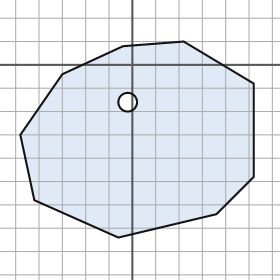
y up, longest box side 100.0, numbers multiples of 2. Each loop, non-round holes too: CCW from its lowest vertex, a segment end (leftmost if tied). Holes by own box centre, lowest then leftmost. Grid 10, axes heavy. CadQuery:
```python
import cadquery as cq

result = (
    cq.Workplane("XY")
    .moveTo(-6.0, -74.0)
    .lineTo(36.0, -64.0)
    .lineTo(52.0, -48.0)
    .lineTo(52.0, -8.0)
    .lineTo(22.0, 10.0)
    .lineTo(-4.0, 8.0)
    .lineTo(-30.0, -4.0)
    .lineTo(-48.0, -30.0)
    .lineTo(-42.0, -58.0)
    .close()
    .moveTo(-2.0, -16.0)
    .circle(4.0)
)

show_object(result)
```